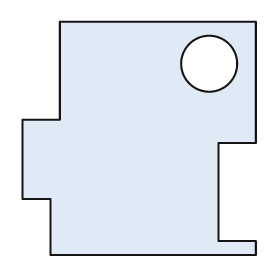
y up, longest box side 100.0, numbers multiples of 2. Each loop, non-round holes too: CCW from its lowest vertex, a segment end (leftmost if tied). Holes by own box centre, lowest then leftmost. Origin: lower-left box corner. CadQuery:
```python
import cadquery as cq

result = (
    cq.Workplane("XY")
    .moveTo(12.0, 0.0)
    .lineTo(100.0, 0.0)
    .lineTo(100.0, 6.0)
    .lineTo(84.0, 6.0)
    .lineTo(84.0, 48.0)
    .lineTo(100.0, 48.0)
    .lineTo(100.0, 100.0)
    .lineTo(16.0, 100.0)
    .lineTo(16.0, 58.0)
    .lineTo(0.0, 58.0)
    .lineTo(0.0, 24.0)
    .lineTo(12.0, 24.0)
    .close()
    .moveTo(80.0, 82.0)
    .circle(12.0)
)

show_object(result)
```